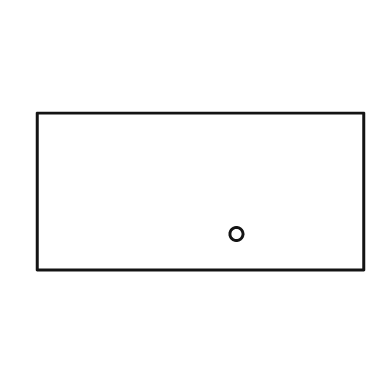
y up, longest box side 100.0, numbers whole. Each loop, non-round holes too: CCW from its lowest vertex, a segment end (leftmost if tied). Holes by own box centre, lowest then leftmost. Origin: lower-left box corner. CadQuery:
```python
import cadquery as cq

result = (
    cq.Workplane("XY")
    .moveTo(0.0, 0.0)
    .lineTo(100.0, 0.0)
    .lineTo(100.0, 48.0)
    .lineTo(0.0, 48.0)
    .close()
    .moveTo(61.0, 11.0)
    .circle(2.0)
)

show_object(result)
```